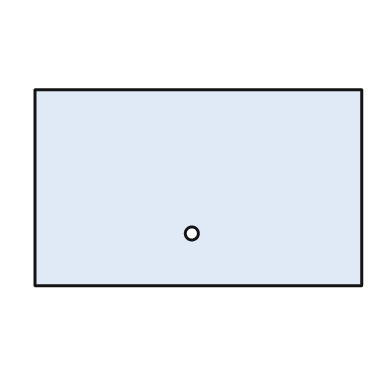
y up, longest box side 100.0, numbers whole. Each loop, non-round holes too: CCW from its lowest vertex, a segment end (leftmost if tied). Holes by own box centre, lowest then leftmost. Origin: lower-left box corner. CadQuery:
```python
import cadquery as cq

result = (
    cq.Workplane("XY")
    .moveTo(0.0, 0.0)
    .lineTo(100.0, 0.0)
    .lineTo(100.0, 60.0)
    .lineTo(0.0, 60.0)
    .close()
    .moveTo(48.0, 16.0)
    .circle(2.0)
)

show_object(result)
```